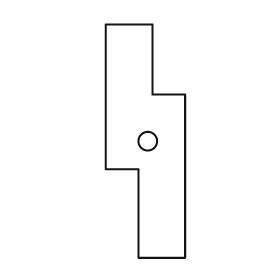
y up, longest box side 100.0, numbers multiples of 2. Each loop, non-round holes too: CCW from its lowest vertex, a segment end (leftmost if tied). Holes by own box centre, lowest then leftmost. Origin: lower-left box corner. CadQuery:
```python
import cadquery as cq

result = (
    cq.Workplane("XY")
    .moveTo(14.0, 0.0)
    .lineTo(34.0, 0.0)
    .lineTo(34.0, 70.0)
    .lineTo(20.0, 70.0)
    .lineTo(20.0, 100.0)
    .lineTo(0.0, 100.0)
    .lineTo(0.0, 38.0)
    .lineTo(14.0, 38.0)
    .close()
    .moveTo(18.0, 50.0)
    .circle(4.0)
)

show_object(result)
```